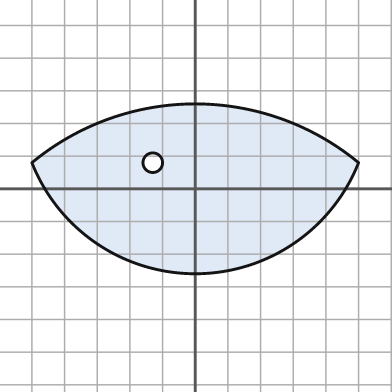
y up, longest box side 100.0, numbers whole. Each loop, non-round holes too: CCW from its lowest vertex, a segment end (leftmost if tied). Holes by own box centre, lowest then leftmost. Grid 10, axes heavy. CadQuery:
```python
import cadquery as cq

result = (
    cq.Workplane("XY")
    .moveTo(-50.0, 8.0)
    .threePointArc((0.0, -26.0), (50.0, 8.0))
    .threePointArc((0.0, 26.0), (-50.0, 8.0))
    .close()
    .moveTo(-13.0, 8.0)
    .circle(3.0)
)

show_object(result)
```